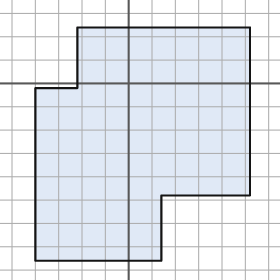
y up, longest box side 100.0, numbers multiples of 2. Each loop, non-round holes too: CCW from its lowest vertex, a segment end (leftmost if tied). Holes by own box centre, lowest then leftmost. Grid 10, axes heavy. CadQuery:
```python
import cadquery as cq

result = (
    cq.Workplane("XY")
    .moveTo(-40.0, -76.0)
    .lineTo(14.0, -76.0)
    .lineTo(14.0, -48.0)
    .lineTo(52.0, -48.0)
    .lineTo(52.0, 24.0)
    .lineTo(-22.0, 24.0)
    .lineTo(-22.0, -2.0)
    .lineTo(-40.0, -2.0)
    .close()
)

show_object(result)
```